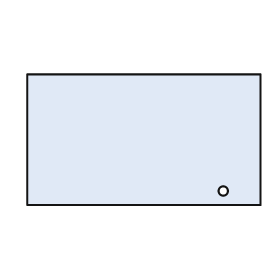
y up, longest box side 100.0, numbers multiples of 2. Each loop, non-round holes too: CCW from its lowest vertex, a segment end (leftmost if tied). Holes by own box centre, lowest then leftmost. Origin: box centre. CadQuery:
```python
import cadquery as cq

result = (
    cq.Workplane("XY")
    .moveTo(-50.0, -28.0)
    .lineTo(50.0, -28.0)
    .lineTo(50.0, 28.0)
    .lineTo(-50.0, 28.0)
    .close()
    .moveTo(34.0, -22.0)
    .circle(2.0)
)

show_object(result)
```